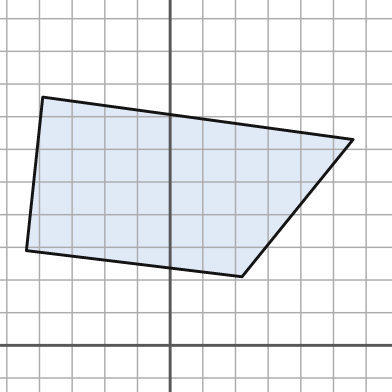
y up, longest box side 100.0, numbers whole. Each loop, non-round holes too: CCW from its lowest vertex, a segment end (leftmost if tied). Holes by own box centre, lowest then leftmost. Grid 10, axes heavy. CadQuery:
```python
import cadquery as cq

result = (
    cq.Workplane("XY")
    .moveTo(22.0, 21.0)
    .lineTo(56.0, 63.0)
    .lineTo(-39.0, 76.0)
    .lineTo(-44.0, 29.0)
    .close()
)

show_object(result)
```